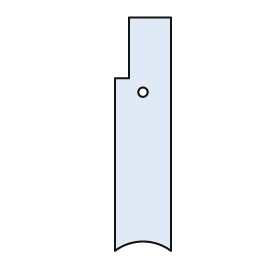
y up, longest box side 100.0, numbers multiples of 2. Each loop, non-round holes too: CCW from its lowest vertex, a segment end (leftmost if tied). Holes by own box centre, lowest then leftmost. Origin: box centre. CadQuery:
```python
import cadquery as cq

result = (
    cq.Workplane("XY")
    .moveTo(-12.0, -50.0)
    .threePointArc((0.0, -46.0), (12.0, -50.0))
    .lineTo(12.0, 50.0)
    .lineTo(-6.0, 50.0)
    .lineTo(-6.0, 24.0)
    .lineTo(-12.0, 24.0)
    .close()
    .moveTo(0.0, 18.0)
    .circle(2.0)
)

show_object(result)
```